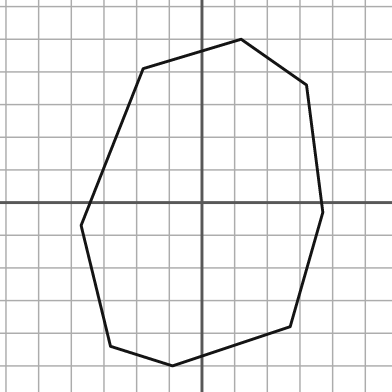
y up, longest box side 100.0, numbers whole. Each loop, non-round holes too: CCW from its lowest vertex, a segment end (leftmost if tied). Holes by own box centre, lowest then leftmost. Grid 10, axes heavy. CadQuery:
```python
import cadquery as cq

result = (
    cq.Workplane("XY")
    .moveTo(-9.0, -50.0)
    .lineTo(27.0, -38.0)
    .lineTo(37.0, -3.0)
    .lineTo(32.0, 36.0)
    .lineTo(12.0, 50.0)
    .lineTo(-18.0, 41.0)
    .lineTo(-37.0, -7.0)
    .lineTo(-28.0, -44.0)
    .close()
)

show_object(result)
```